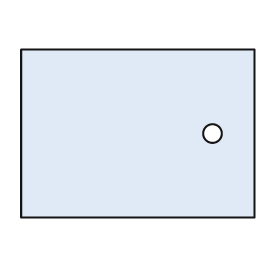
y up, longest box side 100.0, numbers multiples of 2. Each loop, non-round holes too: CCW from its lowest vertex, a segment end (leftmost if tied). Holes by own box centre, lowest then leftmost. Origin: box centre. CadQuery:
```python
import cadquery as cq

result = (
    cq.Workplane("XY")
    .moveTo(-50.0, -36.0)
    .lineTo(50.0, -36.0)
    .lineTo(50.0, 36.0)
    .lineTo(-50.0, 36.0)
    .close()
    .moveTo(32.0, 0.0)
    .circle(4.0)
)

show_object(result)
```